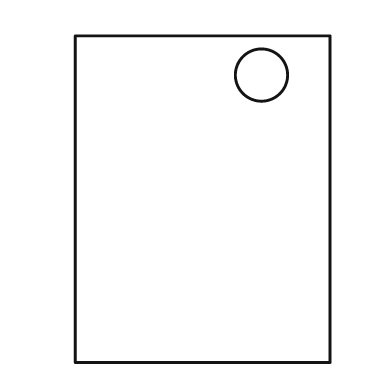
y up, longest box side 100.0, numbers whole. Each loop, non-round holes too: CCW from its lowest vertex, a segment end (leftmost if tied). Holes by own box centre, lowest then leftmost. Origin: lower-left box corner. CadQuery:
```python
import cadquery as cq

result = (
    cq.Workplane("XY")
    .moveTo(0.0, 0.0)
    .lineTo(78.0, 0.0)
    .lineTo(78.0, 100.0)
    .lineTo(0.0, 100.0)
    .close()
    .moveTo(57.0, 88.0)
    .circle(8.0)
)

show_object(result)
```